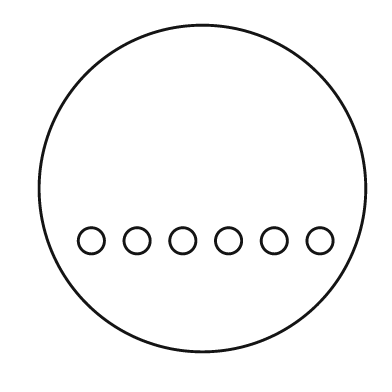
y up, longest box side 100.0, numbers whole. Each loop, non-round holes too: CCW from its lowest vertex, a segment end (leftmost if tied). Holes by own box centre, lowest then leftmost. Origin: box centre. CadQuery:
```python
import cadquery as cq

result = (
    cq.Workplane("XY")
    .moveTo(0.0, 0.0)
    .circle(50.0)
    .moveTo(-34.0, -16.0)
    .circle(4.0)
    .moveTo(-20.0, -16.0)
    .circle(4.0)
    .moveTo(-6.0, -16.0)
    .circle(4.0)
    .moveTo(8.0, -16.0)
    .circle(4.0)
    .moveTo(22.0, -16.0)
    .circle(4.0)
    .moveTo(36.0, -16.0)
    .circle(4.0)
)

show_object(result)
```